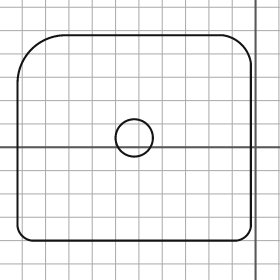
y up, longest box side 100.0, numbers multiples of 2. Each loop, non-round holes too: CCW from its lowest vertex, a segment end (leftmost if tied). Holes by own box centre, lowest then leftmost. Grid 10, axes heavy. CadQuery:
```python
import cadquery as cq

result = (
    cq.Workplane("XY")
    .moveTo(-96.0, -40.0)
    .lineTo(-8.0, -40.0)
    .threePointArc((-4.0, -38.0), (-2.0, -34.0))
    .lineTo(-2.0, 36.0)
    .threePointArc((-6.0, 44.0), (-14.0, 48.0))
    .lineTo(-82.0, 48.0)
    .threePointArc((-96.0, 42.0), (-102.0, 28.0))
    .lineTo(-102.0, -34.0)
    .threePointArc((-100.0, -38.0), (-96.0, -40.0))
    .close()
    .moveTo(-52.0, 4.0)
    .circle(8.0)
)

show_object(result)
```